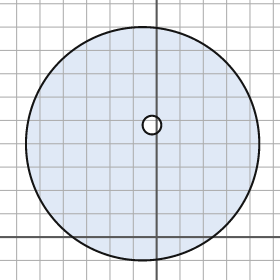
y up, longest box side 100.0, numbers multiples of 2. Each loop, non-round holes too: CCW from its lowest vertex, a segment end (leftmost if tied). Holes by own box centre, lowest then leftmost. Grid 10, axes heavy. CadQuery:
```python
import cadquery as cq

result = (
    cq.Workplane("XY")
    .moveTo(-6.0, 40.0)
    .circle(50.0)
    .moveTo(-2.0, 48.0)
    .circle(4.0)
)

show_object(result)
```